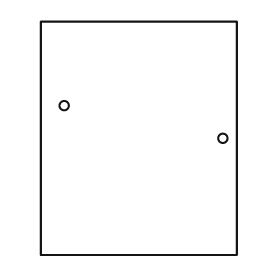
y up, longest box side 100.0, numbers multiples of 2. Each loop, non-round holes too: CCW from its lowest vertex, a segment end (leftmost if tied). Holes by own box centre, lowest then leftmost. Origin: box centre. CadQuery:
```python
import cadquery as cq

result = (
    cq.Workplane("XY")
    .moveTo(-42.0, -50.0)
    .lineTo(42.0, -50.0)
    .lineTo(42.0, 50.0)
    .lineTo(-42.0, 50.0)
    .close()
    .moveTo(36.0, 0.0)
    .circle(2.0)
    .moveTo(-32.0, 14.0)
    .circle(2.0)
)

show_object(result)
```